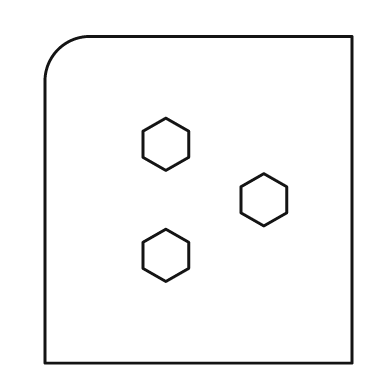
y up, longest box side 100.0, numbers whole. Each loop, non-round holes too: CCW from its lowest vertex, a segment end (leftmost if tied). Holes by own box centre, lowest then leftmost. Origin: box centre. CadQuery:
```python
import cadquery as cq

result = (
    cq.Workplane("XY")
    .moveTo(-47.0, -50.0)
    .lineTo(47.0, -50.0)
    .lineTo(47.0, 50.0)
    .lineTo(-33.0, 50.0)
    .threePointArc((-43.0, 46.0), (-47.0, 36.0))
    .close()
    .moveTo(-10.0, -25.0)
    .lineTo(-3.0, -21.0)
    .lineTo(-3.0, -13.0)
    .lineTo(-10.0, -9.0)
    .lineTo(-17.0, -13.0)
    .lineTo(-17.0, -21.0)
    .close()
    .moveTo(20.0, -8.0)
    .lineTo(27.0, -4.0)
    .lineTo(27.0, 4.0)
    .lineTo(20.0, 8.0)
    .lineTo(13.0, 4.0)
    .lineTo(13.0, -4.0)
    .close()
    .moveTo(-10.0, 9.0)
    .lineTo(-3.0, 13.0)
    .lineTo(-3.0, 21.0)
    .lineTo(-10.0, 25.0)
    .lineTo(-17.0, 21.0)
    .lineTo(-17.0, 13.0)
    .close()
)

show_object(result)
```